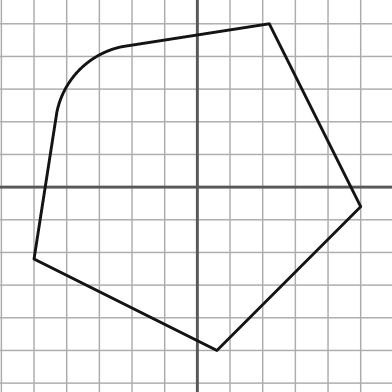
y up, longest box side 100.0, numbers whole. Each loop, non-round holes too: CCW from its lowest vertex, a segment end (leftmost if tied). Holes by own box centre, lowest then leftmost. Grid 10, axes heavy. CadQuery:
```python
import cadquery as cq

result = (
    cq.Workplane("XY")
    .moveTo(6.0, -50.0)
    .lineTo(50.0, -6.0)
    .lineTo(22.0, 50.0)
    .lineTo(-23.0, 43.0)
    .threePointArc((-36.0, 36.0), (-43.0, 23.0))
    .lineTo(-50.0, -22.0)
    .close()
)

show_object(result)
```